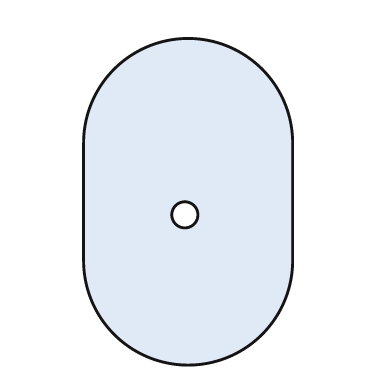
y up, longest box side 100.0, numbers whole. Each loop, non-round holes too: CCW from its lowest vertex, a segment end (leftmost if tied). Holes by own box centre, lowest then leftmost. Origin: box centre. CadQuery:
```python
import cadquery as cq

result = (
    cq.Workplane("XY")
    .moveTo(-32.0, -18.0)
    .threePointArc((0.0, -50.0), (32.0, -18.0))
    .lineTo(32.0, 18.0)
    .threePointArc((0.0, 50.0), (-32.0, 18.0))
    .close()
    .moveTo(-1.0, -4.0)
    .circle(4.0)
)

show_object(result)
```